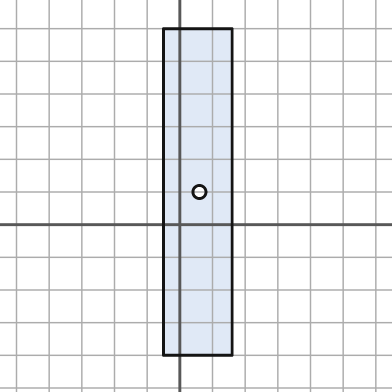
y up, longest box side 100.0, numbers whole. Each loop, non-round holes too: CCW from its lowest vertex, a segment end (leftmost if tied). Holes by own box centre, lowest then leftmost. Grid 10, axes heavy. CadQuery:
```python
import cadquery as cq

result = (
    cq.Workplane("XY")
    .moveTo(-5.0, -40.0)
    .lineTo(16.0, -40.0)
    .lineTo(16.0, 60.0)
    .lineTo(-5.0, 60.0)
    .close()
    .moveTo(6.0, 10.0)
    .circle(2.0)
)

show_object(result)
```